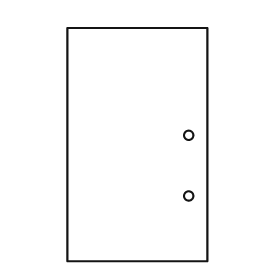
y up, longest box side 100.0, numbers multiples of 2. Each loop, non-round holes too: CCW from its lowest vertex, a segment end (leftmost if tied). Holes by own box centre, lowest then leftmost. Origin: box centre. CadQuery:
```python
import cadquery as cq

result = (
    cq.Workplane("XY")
    .moveTo(-30.0, -50.0)
    .lineTo(30.0, -50.0)
    .lineTo(30.0, 50.0)
    .lineTo(-30.0, 50.0)
    .close()
    .moveTo(22.0, -22.0)
    .circle(2.0)
    .moveTo(22.0, 4.0)
    .circle(2.0)
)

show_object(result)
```